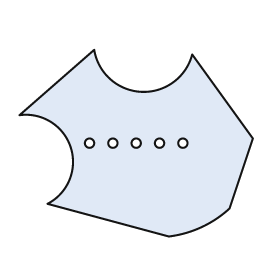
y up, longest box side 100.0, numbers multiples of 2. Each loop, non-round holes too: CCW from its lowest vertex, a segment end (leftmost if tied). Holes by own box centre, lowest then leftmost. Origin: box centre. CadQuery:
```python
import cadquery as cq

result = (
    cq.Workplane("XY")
    .moveTo(14.0, -40.0)
    .threePointArc((28.0, -36.0), (40.0, -28.0))
    .lineTo(50.0, 2.0)
    .lineTo(24.0, 38.0)
    .threePointArc((2.0, 22.0), (-18.0, 40.0))
    .lineTo(-50.0, 12.0)
    .threePointArc((-28.0, -2.0), (-38.0, -26.0))
    .close()
    .moveTo(-20.0, 0.0)
    .circle(2.0)
    .moveTo(-10.0, 0.0)
    .circle(2.0)
    .moveTo(0.0, 0.0)
    .circle(2.0)
    .moveTo(10.0, 0.0)
    .circle(2.0)
    .moveTo(20.0, 0.0)
    .circle(2.0)
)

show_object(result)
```